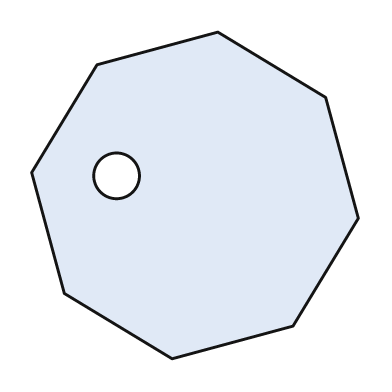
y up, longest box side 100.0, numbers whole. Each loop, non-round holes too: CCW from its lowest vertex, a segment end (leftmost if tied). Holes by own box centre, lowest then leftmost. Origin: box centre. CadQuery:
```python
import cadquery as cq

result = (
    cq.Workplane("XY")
    .moveTo(-7.0, -50.0)
    .lineTo(30.0, -40.0)
    .lineTo(50.0, -7.0)
    .lineTo(40.0, 30.0)
    .lineTo(7.0, 50.0)
    .lineTo(-30.0, 40.0)
    .lineTo(-50.0, 7.0)
    .lineTo(-40.0, -30.0)
    .close()
    .moveTo(-24.0, 6.0)
    .circle(7.0)
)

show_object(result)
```